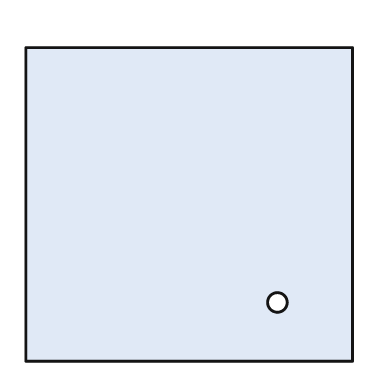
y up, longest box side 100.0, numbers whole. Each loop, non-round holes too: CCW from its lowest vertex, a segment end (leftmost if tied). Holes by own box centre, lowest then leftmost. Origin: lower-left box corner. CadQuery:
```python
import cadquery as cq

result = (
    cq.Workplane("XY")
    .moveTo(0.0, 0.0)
    .lineTo(100.0, 0.0)
    .lineTo(100.0, 96.0)
    .lineTo(0.0, 96.0)
    .close()
    .moveTo(77.0, 18.0)
    .circle(3.0)
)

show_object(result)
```